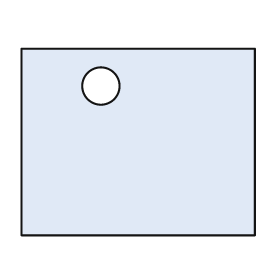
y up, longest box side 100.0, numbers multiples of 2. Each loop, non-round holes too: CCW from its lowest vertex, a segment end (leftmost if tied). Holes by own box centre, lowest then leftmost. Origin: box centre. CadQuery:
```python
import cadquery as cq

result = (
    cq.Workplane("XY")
    .moveTo(-50.0, -40.0)
    .lineTo(50.0, -40.0)
    .lineTo(50.0, 40.0)
    .lineTo(-50.0, 40.0)
    .close()
    .moveTo(-16.0, 24.0)
    .circle(8.0)
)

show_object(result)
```